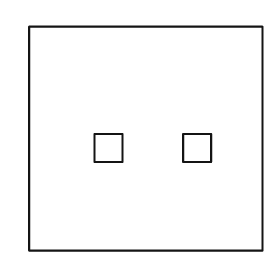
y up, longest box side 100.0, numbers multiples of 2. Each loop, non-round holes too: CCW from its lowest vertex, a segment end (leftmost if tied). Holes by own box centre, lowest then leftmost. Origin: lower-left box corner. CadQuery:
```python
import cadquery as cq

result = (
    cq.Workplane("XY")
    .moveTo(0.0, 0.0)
    .lineTo(100.0, 0.0)
    .lineTo(100.0, 96.0)
    .lineTo(0.0, 96.0)
    .close()
    .moveTo(28.0, 38.0)
    .lineTo(40.0, 38.0)
    .lineTo(40.0, 50.0)
    .lineTo(28.0, 50.0)
    .close()
    .moveTo(66.0, 38.0)
    .lineTo(78.0, 38.0)
    .lineTo(78.0, 50.0)
    .lineTo(66.0, 50.0)
    .close()
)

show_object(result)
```